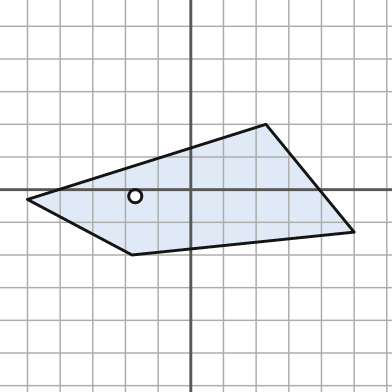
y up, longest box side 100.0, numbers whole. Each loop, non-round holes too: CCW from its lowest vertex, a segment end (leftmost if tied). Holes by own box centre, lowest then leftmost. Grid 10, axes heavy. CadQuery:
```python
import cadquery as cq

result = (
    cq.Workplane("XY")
    .moveTo(-18.0, -20.0)
    .lineTo(50.0, -13.0)
    .lineTo(23.0, 20.0)
    .lineTo(-50.0, -3.0)
    .close()
    .moveTo(-17.0, -2.0)
    .circle(2.0)
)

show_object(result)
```